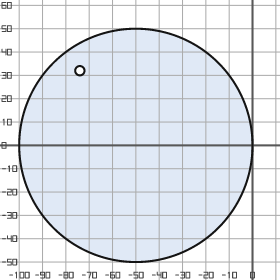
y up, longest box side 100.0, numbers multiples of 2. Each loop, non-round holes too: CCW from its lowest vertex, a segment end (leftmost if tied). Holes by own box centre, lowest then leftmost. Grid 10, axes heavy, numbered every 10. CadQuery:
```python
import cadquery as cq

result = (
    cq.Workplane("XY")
    .moveTo(-50.0, 0.0)
    .circle(50.0)
    .moveTo(-74.0, 32.0)
    .circle(2.0)
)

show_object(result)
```